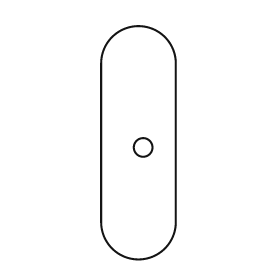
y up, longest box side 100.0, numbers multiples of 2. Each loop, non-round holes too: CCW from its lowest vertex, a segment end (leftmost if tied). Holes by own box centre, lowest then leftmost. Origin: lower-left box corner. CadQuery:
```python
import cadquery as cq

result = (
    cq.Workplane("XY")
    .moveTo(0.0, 16.0)
    .threePointArc((16.0, 0.0), (32.0, 16.0))
    .lineTo(32.0, 84.0)
    .threePointArc((16.0, 100.0), (0.0, 84.0))
    .close()
    .moveTo(18.0, 48.0)
    .circle(4.0)
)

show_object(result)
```